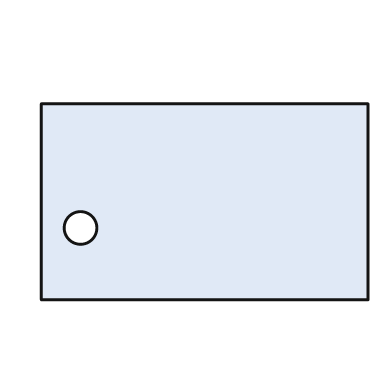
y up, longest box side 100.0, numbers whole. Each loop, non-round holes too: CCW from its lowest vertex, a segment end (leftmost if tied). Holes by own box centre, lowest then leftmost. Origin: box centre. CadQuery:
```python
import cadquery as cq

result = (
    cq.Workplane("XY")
    .moveTo(-50.0, -30.0)
    .lineTo(50.0, -30.0)
    .lineTo(50.0, 30.0)
    .lineTo(-50.0, 30.0)
    .close()
    .moveTo(-38.0, -8.0)
    .circle(5.0)
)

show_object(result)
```